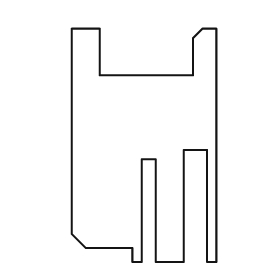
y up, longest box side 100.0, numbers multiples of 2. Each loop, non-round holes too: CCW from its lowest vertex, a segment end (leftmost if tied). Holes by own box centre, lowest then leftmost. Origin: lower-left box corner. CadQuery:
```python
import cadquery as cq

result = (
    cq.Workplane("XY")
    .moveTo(26.0, 0.0)
    .lineTo(30.0, 0.0)
    .lineTo(30.0, 44.0)
    .lineTo(36.0, 44.0)
    .lineTo(36.0, 0.0)
    .lineTo(48.0, 0.0)
    .lineTo(48.0, 48.0)
    .lineTo(58.0, 48.0)
    .lineTo(58.0, 0.0)
    .lineTo(62.0, 0.0)
    .lineTo(62.0, 100.0)
    .lineTo(56.0, 100.0)
    .lineTo(52.0, 96.0)
    .lineTo(52.0, 80.0)
    .lineTo(12.0, 80.0)
    .lineTo(12.0, 100.0)
    .lineTo(0.0, 100.0)
    .lineTo(0.0, 12.0)
    .lineTo(6.0, 6.0)
    .lineTo(26.0, 6.0)
    .close()
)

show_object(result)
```